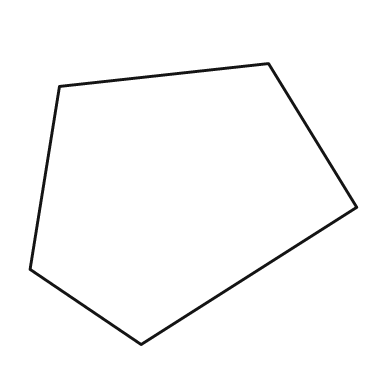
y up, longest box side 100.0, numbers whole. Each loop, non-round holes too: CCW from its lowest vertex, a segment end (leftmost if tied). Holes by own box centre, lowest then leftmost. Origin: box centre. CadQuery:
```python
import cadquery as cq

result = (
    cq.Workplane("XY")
    .moveTo(-16.0, -43.0)
    .lineTo(50.0, -1.0)
    .lineTo(23.0, 43.0)
    .lineTo(-41.0, 36.0)
    .lineTo(-50.0, -20.0)
    .close()
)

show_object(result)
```